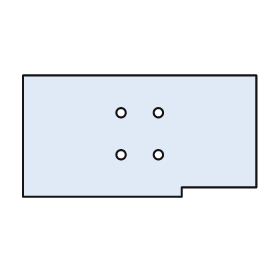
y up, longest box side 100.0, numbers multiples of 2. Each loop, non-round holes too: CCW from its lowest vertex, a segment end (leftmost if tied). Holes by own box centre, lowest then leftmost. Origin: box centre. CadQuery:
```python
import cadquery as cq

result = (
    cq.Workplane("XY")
    .moveTo(-50.0, -26.0)
    .lineTo(18.0, -26.0)
    .lineTo(18.0, -22.0)
    .lineTo(50.0, -22.0)
    .lineTo(50.0, 26.0)
    .lineTo(-50.0, 26.0)
    .close()
    .moveTo(-8.0, -8.0)
    .circle(2.0)
    .moveTo(8.0, -8.0)
    .circle(2.0)
    .moveTo(-8.0, 10.0)
    .circle(2.0)
    .moveTo(8.0, 10.0)
    .circle(2.0)
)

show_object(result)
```